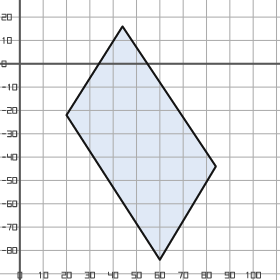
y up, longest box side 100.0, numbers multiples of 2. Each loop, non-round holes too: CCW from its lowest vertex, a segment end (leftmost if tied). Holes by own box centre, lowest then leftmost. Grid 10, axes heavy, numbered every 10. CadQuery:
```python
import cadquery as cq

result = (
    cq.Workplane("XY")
    .moveTo(60.0, -84.0)
    .lineTo(84.0, -44.0)
    .lineTo(44.0, 16.0)
    .lineTo(20.0, -22.0)
    .close()
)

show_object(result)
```